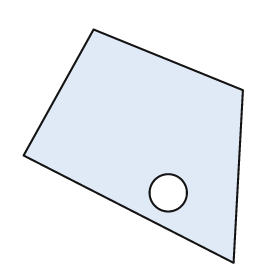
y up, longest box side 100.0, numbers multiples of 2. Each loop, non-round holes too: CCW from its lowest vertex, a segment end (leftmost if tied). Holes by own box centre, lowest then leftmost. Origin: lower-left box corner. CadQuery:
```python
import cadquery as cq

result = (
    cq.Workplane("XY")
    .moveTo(90.0, 0.0)
    .lineTo(94.0, 74.0)
    .lineTo(30.0, 100.0)
    .lineTo(0.0, 46.0)
    .close()
    .moveTo(62.0, 30.0)
    .circle(8.0)
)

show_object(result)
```